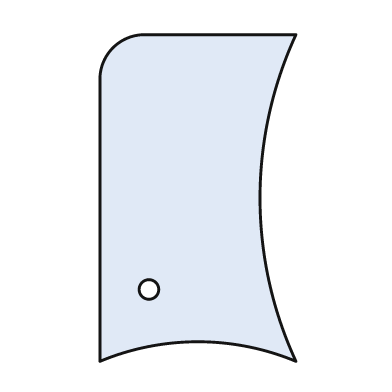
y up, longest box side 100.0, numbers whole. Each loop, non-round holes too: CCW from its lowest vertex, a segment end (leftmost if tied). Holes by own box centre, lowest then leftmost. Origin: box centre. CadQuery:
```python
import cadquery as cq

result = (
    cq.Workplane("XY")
    .moveTo(-30.0, -50.0)
    .threePointArc((0.0, -44.0), (30.0, -50.0))
    .threePointArc((19.0, 0.0), (30.0, 50.0))
    .lineTo(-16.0, 50.0)
    .threePointArc((-26.0, 46.0), (-30.0, 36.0))
    .close()
    .moveTo(-15.0, -28.0)
    .circle(3.0)
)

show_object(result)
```